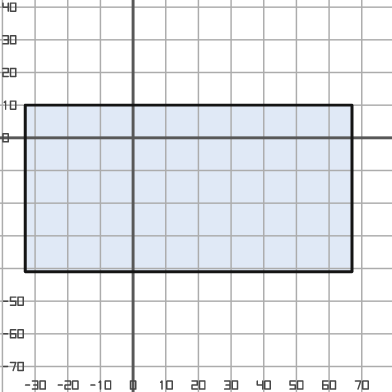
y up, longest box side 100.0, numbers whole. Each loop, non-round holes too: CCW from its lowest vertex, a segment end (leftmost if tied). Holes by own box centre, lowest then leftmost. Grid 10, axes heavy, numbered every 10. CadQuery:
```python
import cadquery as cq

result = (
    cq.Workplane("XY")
    .moveTo(-33.0, -41.0)
    .lineTo(67.0, -41.0)
    .lineTo(67.0, 10.0)
    .lineTo(-33.0, 10.0)
    .close()
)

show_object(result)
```